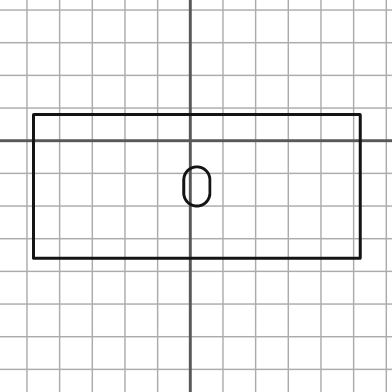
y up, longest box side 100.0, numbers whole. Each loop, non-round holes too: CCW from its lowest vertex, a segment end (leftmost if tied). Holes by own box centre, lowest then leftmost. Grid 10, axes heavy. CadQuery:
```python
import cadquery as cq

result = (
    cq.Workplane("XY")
    .moveTo(-48.0, -36.0)
    .lineTo(52.0, -36.0)
    .lineTo(52.0, 8.0)
    .lineTo(-48.0, 8.0)
    .close()
    .moveTo(-2.0, -16.0)
    .threePointArc((2.0, -20.0), (6.0, -16.0))
    .lineTo(6.0, -12.0)
    .threePointArc((2.0, -8.0), (-2.0, -12.0))
    .close()
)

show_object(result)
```